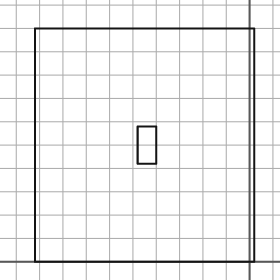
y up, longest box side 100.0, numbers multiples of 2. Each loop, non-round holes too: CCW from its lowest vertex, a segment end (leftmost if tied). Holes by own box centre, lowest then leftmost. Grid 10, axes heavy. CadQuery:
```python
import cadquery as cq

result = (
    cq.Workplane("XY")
    .moveTo(-92.0, 0.0)
    .lineTo(2.0, 0.0)
    .lineTo(2.0, 100.0)
    .lineTo(-92.0, 100.0)
    .close()
    .moveTo(-48.0, 42.0)
    .lineTo(-40.0, 42.0)
    .lineTo(-40.0, 58.0)
    .lineTo(-48.0, 58.0)
    .close()
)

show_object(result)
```